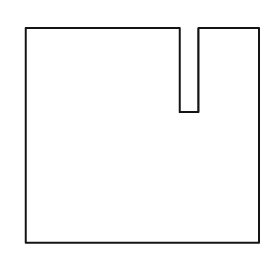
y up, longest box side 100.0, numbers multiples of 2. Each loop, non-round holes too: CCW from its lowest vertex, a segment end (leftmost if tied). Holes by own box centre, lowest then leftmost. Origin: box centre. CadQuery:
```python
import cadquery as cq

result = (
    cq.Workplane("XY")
    .moveTo(-50.0, -46.0)
    .lineTo(50.0, -46.0)
    .lineTo(50.0, 46.0)
    .lineTo(24.0, 46.0)
    .lineTo(24.0, 10.0)
    .lineTo(16.0, 10.0)
    .lineTo(16.0, 46.0)
    .lineTo(-50.0, 46.0)
    .close()
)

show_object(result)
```